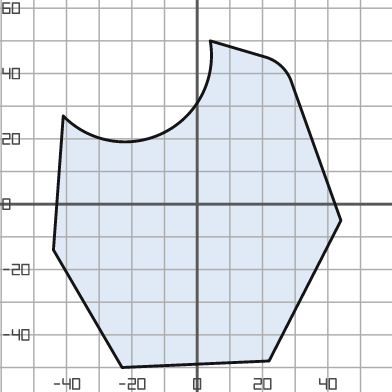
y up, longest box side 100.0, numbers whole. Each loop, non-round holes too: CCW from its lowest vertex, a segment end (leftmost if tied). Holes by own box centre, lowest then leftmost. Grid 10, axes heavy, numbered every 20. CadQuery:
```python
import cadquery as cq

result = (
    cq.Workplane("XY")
    .moveTo(-23.0, -50.0)
    .lineTo(22.0, -48.0)
    .lineTo(44.0, -5.0)
    .lineTo(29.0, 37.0)
    .threePointArc((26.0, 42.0), (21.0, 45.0))
    .lineTo(4.0, 50.0)
    .threePointArc((-10.0, 22.0), (-41.0, 27.0))
    .lineTo(-44.0, -14.0)
    .close()
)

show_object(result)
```